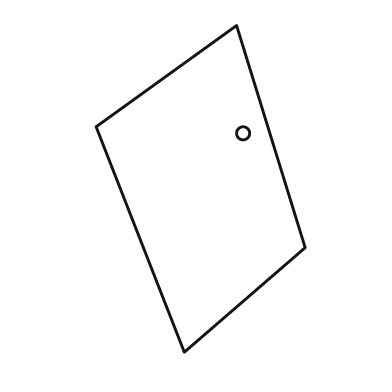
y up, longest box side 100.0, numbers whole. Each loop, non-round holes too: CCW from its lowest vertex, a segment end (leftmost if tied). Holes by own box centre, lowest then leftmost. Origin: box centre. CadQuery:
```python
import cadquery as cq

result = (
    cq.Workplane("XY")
    .moveTo(-5.0, -50.0)
    .lineTo(32.0, -18.0)
    .lineTo(11.0, 50.0)
    .lineTo(-32.0, 19.0)
    .close()
    .moveTo(13.0, 17.0)
    .circle(2.0)
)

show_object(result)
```